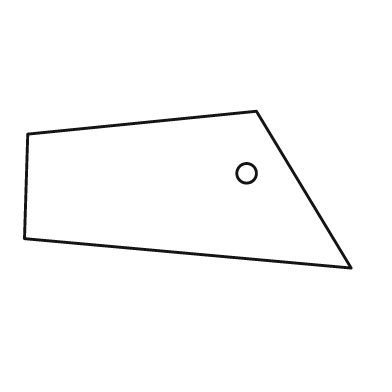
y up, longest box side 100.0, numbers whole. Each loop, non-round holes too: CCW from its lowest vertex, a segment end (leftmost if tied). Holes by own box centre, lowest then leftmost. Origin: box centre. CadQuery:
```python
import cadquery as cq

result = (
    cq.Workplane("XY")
    .moveTo(50.0, -24.0)
    .lineTo(21.0, 24.0)
    .lineTo(-49.0, 17.0)
    .lineTo(-50.0, -15.0)
    .close()
    .moveTo(18.0, 5.0)
    .circle(3.0)
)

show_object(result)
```